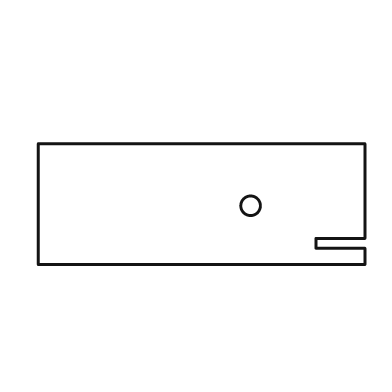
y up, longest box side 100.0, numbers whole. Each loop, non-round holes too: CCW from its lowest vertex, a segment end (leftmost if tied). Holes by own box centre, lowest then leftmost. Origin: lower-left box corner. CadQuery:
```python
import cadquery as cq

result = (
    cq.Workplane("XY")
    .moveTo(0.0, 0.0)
    .lineTo(100.0, 0.0)
    .lineTo(100.0, 5.0)
    .lineTo(85.0, 5.0)
    .lineTo(85.0, 8.0)
    .lineTo(100.0, 8.0)
    .lineTo(100.0, 37.0)
    .lineTo(0.0, 37.0)
    .close()
    .moveTo(65.0, 18.0)
    .circle(3.0)
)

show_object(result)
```